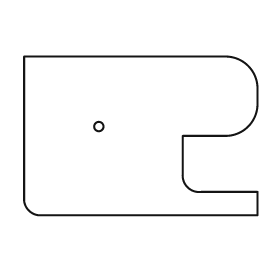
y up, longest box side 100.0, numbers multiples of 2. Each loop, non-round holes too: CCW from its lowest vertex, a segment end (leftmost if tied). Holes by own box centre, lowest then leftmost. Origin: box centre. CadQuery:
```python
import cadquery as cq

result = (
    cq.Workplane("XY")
    .moveTo(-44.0, -34.0)
    .lineTo(50.0, -34.0)
    .lineTo(50.0, -24.0)
    .lineTo(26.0, -24.0)
    .threePointArc((20.0, -22.0), (18.0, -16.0))
    .lineTo(18.0, 0.0)
    .lineTo(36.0, 0.0)
    .threePointArc((46.0, 4.0), (50.0, 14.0))
    .lineTo(50.0, 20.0)
    .threePointArc((46.0, 30.0), (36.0, 34.0))
    .lineTo(-50.0, 34.0)
    .lineTo(-50.0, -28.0)
    .threePointArc((-48.0, -32.0), (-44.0, -34.0))
    .close()
    .moveTo(-18.0, 4.0)
    .circle(2.0)
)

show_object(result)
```